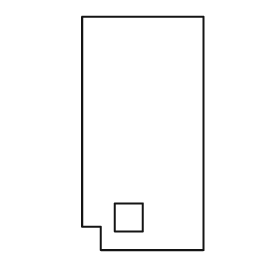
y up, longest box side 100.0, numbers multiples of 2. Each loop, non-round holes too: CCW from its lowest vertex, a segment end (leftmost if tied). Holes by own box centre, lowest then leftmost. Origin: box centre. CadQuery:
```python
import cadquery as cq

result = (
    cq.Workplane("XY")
    .moveTo(-18.0, -50.0)
    .lineTo(26.0, -50.0)
    .lineTo(26.0, 50.0)
    .lineTo(-26.0, 50.0)
    .lineTo(-26.0, -40.0)
    .lineTo(-18.0, -40.0)
    .close()
    .moveTo(-12.0, -42.0)
    .lineTo(0.0, -42.0)
    .lineTo(0.0, -30.0)
    .lineTo(-12.0, -30.0)
    .close()
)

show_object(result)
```